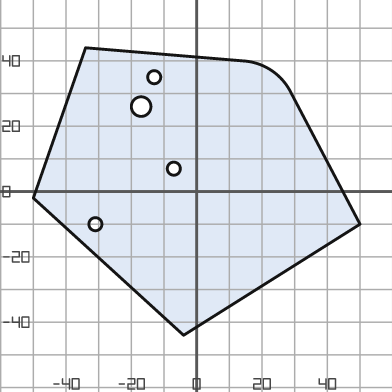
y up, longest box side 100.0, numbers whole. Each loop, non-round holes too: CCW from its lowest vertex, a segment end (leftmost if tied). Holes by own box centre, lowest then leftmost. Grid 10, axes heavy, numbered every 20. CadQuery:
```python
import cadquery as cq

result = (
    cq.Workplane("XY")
    .moveTo(-4.0, -44.0)
    .lineTo(50.0, -10.0)
    .lineTo(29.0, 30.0)
    .threePointArc((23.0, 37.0), (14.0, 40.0))
    .lineTo(-34.0, 44.0)
    .lineTo(-50.0, -2.0)
    .close()
    .moveTo(-31.0, -10.0)
    .circle(2.0)
    .moveTo(-7.0, 7.0)
    .circle(2.0)
    .moveTo(-17.0, 26.0)
    .circle(3.0)
    .moveTo(-13.0, 35.0)
    .circle(2.0)
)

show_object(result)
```